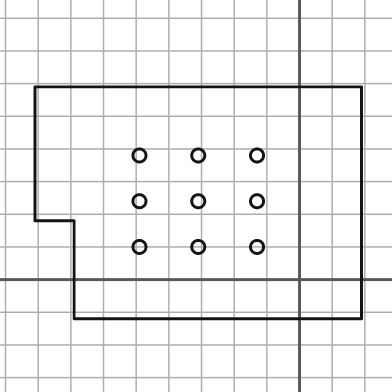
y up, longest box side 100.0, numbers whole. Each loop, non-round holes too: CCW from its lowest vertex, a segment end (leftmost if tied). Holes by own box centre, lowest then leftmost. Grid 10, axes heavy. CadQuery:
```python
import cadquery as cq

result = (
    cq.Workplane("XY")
    .moveTo(-69.0, -12.0)
    .lineTo(19.0, -12.0)
    .lineTo(19.0, 59.0)
    .lineTo(-81.0, 59.0)
    .lineTo(-81.0, 18.0)
    .lineTo(-69.0, 18.0)
    .close()
    .moveTo(-49.0, 10.0)
    .circle(2.0)
    .moveTo(-31.0, 10.0)
    .circle(2.0)
    .moveTo(-13.0, 10.0)
    .circle(2.0)
    .moveTo(-49.0, 24.0)
    .circle(2.0)
    .moveTo(-31.0, 24.0)
    .circle(2.0)
    .moveTo(-13.0, 24.0)
    .circle(2.0)
    .moveTo(-49.0, 38.0)
    .circle(2.0)
    .moveTo(-31.0, 38.0)
    .circle(2.0)
    .moveTo(-13.0, 38.0)
    .circle(2.0)
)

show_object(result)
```